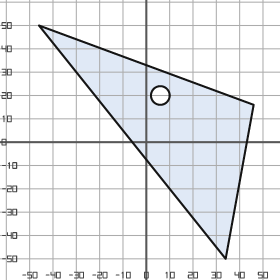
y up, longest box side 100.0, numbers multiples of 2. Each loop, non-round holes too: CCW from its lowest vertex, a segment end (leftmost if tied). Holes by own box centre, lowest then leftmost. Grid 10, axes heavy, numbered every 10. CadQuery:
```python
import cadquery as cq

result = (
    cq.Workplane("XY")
    .moveTo(34.0, -50.0)
    .lineTo(46.0, 16.0)
    .lineTo(-46.0, 50.0)
    .close()
    .moveTo(6.0, 20.0)
    .circle(4.0)
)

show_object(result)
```